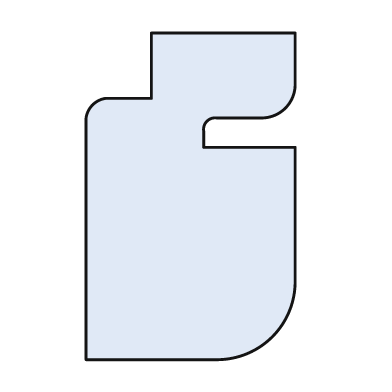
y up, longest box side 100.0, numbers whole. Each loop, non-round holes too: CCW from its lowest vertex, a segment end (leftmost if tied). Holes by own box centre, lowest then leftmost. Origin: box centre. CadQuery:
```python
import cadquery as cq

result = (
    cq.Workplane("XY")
    .moveTo(-32.0, -50.0)
    .lineTo(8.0, -50.0)
    .threePointArc((25.0, -43.0), (32.0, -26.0))
    .lineTo(32.0, 15.0)
    .lineTo(4.0, 15.0)
    .lineTo(4.0, 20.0)
    .threePointArc((5.0, 23.0), (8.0, 24.0))
    .lineTo(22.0, 24.0)
    .threePointArc((29.0, 27.0), (32.0, 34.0))
    .lineTo(32.0, 50.0)
    .lineTo(-12.0, 50.0)
    .lineTo(-12.0, 30.0)
    .lineTo(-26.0, 30.0)
    .threePointArc((-30.0, 28.0), (-32.0, 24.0))
    .close()
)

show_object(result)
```